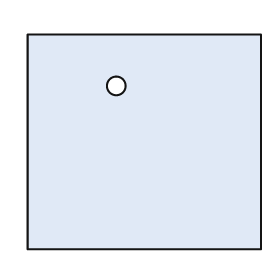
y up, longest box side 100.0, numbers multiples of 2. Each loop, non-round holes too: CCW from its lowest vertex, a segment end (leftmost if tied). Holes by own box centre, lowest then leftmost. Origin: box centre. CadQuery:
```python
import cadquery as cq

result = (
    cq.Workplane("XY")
    .moveTo(-50.0, -46.0)
    .lineTo(50.0, -46.0)
    .lineTo(50.0, 46.0)
    .lineTo(-50.0, 46.0)
    .close()
    .moveTo(-12.0, 24.0)
    .circle(4.0)
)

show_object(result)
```